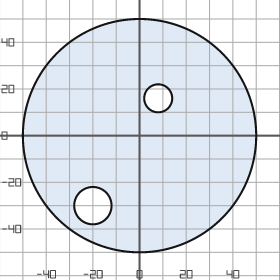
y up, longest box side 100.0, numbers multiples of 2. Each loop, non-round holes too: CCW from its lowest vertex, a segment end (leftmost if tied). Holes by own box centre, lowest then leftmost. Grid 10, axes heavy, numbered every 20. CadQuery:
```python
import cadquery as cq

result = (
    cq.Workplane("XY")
    .moveTo(0.0, 0.0)
    .circle(50.0)
    .moveTo(-20.0, -30.0)
    .circle(8.0)
    .moveTo(8.0, 16.0)
    .circle(6.0)
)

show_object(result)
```